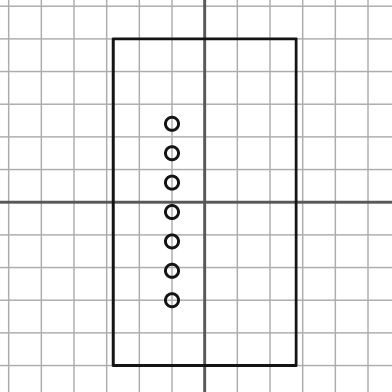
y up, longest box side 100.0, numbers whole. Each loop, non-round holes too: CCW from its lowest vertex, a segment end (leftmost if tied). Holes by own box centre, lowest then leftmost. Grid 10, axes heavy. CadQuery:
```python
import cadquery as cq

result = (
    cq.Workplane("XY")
    .moveTo(-28.0, -50.0)
    .lineTo(28.0, -50.0)
    .lineTo(28.0, 50.0)
    .lineTo(-28.0, 50.0)
    .close()
    .moveTo(-10.0, -30.0)
    .circle(2.0)
    .moveTo(-10.0, -21.0)
    .circle(2.0)
    .moveTo(-10.0, -12.0)
    .circle(2.0)
    .moveTo(-10.0, -3.0)
    .circle(2.0)
    .moveTo(-10.0, 6.0)
    .circle(2.0)
    .moveTo(-10.0, 15.0)
    .circle(2.0)
    .moveTo(-10.0, 24.0)
    .circle(2.0)
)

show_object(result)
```